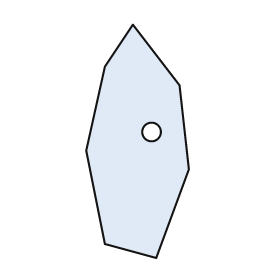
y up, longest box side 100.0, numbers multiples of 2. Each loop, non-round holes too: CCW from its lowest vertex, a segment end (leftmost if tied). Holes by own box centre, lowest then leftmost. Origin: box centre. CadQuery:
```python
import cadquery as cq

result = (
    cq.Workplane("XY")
    .moveTo(8.0, -50.0)
    .lineTo(22.0, -12.0)
    .lineTo(18.0, 24.0)
    .lineTo(-2.0, 50.0)
    .lineTo(-14.0, 32.0)
    .lineTo(-22.0, -4.0)
    .lineTo(-14.0, -44.0)
    .close()
    .moveTo(6.0, 4.0)
    .circle(4.0)
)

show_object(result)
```